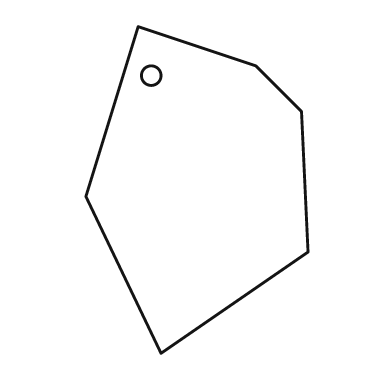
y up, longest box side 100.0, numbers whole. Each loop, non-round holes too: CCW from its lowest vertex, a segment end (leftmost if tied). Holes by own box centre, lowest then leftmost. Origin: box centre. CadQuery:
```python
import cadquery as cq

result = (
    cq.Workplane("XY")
    .moveTo(-11.0, -50.0)
    .lineTo(34.0, -19.0)
    .lineTo(32.0, 24.0)
    .lineTo(18.0, 38.0)
    .lineTo(-18.0, 50.0)
    .lineTo(-34.0, -2.0)
    .close()
    .moveTo(-14.0, 35.0)
    .circle(3.0)
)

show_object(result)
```